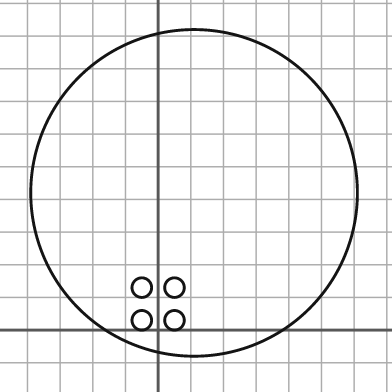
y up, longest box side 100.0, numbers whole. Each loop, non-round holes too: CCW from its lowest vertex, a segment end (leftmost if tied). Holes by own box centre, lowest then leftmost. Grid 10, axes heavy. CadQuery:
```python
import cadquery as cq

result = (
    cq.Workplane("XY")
    .moveTo(11.0, 42.0)
    .circle(50.0)
    .moveTo(-5.0, 3.0)
    .circle(3.0)
    .moveTo(5.0, 3.0)
    .circle(3.0)
    .moveTo(-5.0, 13.0)
    .circle(3.0)
    .moveTo(5.0, 13.0)
    .circle(3.0)
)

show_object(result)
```